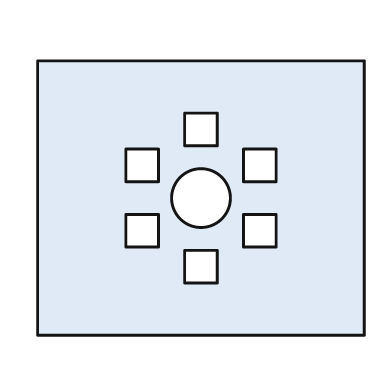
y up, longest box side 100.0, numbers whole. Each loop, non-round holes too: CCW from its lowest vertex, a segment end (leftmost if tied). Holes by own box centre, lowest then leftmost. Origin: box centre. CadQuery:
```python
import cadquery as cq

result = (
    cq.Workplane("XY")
    .moveTo(-50.0, -42.0)
    .lineTo(50.0, -42.0)
    .lineTo(50.0, 42.0)
    .lineTo(-50.0, 42.0)
    .close()
    .moveTo(-5.0, -26.0)
    .lineTo(5.0, -26.0)
    .lineTo(5.0, -16.0)
    .lineTo(-5.0, -16.0)
    .close()
    .moveTo(-23.0, -15.0)
    .lineTo(-13.0, -15.0)
    .lineTo(-13.0, -5.0)
    .lineTo(-23.0, -5.0)
    .close()
    .moveTo(13.0, -15.0)
    .lineTo(23.0, -15.0)
    .lineTo(23.0, -5.0)
    .lineTo(13.0, -5.0)
    .close()
    .moveTo(0.0, 0.0)
    .circle(9.0)
    .moveTo(-23.0, 5.0)
    .lineTo(-13.0, 5.0)
    .lineTo(-13.0, 15.0)
    .lineTo(-23.0, 15.0)
    .close()
    .moveTo(13.0, 5.0)
    .lineTo(23.0, 5.0)
    .lineTo(23.0, 15.0)
    .lineTo(13.0, 15.0)
    .close()
    .moveTo(-5.0, 16.0)
    .lineTo(5.0, 16.0)
    .lineTo(5.0, 26.0)
    .lineTo(-5.0, 26.0)
    .close()
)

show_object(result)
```